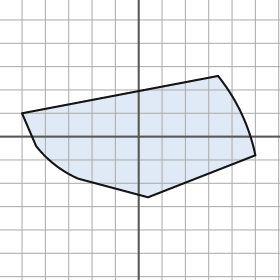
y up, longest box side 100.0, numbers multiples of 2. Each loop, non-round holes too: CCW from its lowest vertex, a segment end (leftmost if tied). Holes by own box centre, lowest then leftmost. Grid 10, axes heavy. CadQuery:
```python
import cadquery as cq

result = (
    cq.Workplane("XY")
    .moveTo(4.0, -26.0)
    .lineTo(50.0, -8.0)
    .threePointArc((44.0, 10.0), (34.0, 26.0))
    .lineTo(-50.0, 10.0)
    .lineTo(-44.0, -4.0)
    .threePointArc((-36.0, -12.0), (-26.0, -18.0))
    .close()
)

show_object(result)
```